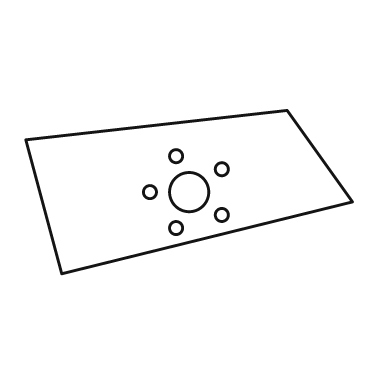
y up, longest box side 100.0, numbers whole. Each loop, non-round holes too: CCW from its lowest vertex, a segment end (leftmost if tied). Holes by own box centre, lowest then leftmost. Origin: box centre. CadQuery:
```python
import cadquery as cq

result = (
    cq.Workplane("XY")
    .moveTo(-39.0, -25.0)
    .lineTo(50.0, -3.0)
    .lineTo(30.0, 25.0)
    .lineTo(-50.0, 16.0)
    .close()
    .moveTo(-4.0, -11.0)
    .circle(2.0)
    .moveTo(10.0, -7.0)
    .circle(2.0)
    .moveTo(-12.0, 0.0)
    .circle(2.0)
    .moveTo(0.0, 0.0)
    .circle(6.0)
    .moveTo(10.0, 7.0)
    .circle(2.0)
    .moveTo(-4.0, 11.0)
    .circle(2.0)
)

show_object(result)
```